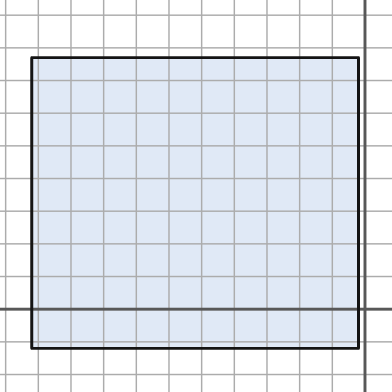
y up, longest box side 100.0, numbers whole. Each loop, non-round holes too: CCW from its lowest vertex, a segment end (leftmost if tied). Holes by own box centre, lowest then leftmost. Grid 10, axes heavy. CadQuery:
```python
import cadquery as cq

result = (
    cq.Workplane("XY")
    .moveTo(-102.0, -12.0)
    .lineTo(-2.0, -12.0)
    .lineTo(-2.0, 77.0)
    .lineTo(-102.0, 77.0)
    .close()
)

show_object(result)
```